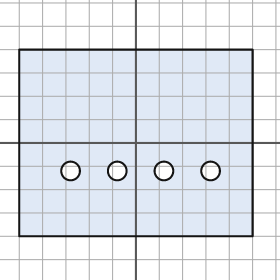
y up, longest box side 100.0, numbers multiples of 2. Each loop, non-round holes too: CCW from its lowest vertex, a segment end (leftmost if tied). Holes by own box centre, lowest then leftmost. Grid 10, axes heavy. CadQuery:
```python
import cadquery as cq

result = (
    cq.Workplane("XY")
    .moveTo(-50.0, -40.0)
    .lineTo(50.0, -40.0)
    .lineTo(50.0, 40.0)
    .lineTo(-50.0, 40.0)
    .close()
    .moveTo(-28.0, -12.0)
    .circle(4.0)
    .moveTo(-8.0, -12.0)
    .circle(4.0)
    .moveTo(12.0, -12.0)
    .circle(4.0)
    .moveTo(32.0, -12.0)
    .circle(4.0)
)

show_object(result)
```